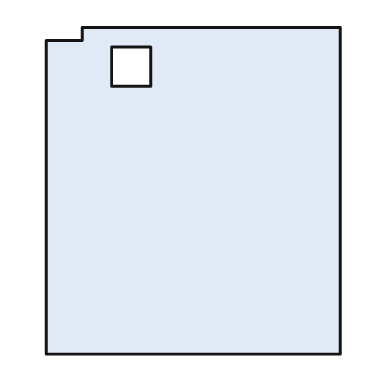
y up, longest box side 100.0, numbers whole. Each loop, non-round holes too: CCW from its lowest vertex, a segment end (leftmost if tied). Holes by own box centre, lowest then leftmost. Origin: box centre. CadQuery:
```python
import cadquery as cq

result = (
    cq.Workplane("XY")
    .moveTo(-45.0, -50.0)
    .lineTo(45.0, -50.0)
    .lineTo(45.0, 50.0)
    .lineTo(-34.0, 50.0)
    .lineTo(-34.0, 46.0)
    .lineTo(-45.0, 46.0)
    .close()
    .moveTo(-25.0, 32.0)
    .lineTo(-13.0, 32.0)
    .lineTo(-13.0, 44.0)
    .lineTo(-25.0, 44.0)
    .close()
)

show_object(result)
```